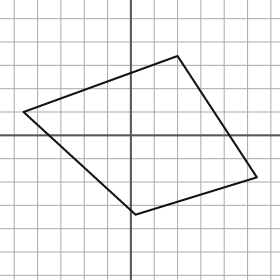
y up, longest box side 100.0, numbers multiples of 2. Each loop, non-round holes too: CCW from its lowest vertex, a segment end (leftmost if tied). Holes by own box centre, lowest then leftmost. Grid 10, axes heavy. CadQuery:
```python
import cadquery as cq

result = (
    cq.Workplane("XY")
    .moveTo(2.0, -34.0)
    .lineTo(54.0, -18.0)
    .lineTo(20.0, 34.0)
    .lineTo(-46.0, 10.0)
    .close()
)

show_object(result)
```